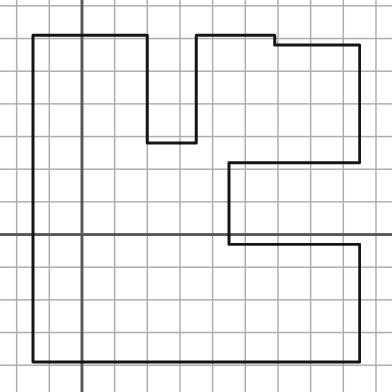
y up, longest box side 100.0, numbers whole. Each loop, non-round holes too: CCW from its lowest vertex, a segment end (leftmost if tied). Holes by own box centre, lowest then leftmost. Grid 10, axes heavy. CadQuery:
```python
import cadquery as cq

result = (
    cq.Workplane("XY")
    .moveTo(-15.0, -39.0)
    .lineTo(85.0, -39.0)
    .lineTo(85.0, -3.0)
    .lineTo(45.0, -3.0)
    .lineTo(45.0, 22.0)
    .lineTo(85.0, 22.0)
    .lineTo(85.0, 58.0)
    .lineTo(59.0, 58.0)
    .lineTo(59.0, 61.0)
    .lineTo(35.0, 61.0)
    .lineTo(35.0, 28.0)
    .lineTo(20.0, 28.0)
    .lineTo(20.0, 61.0)
    .lineTo(-15.0, 61.0)
    .close()
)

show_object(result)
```